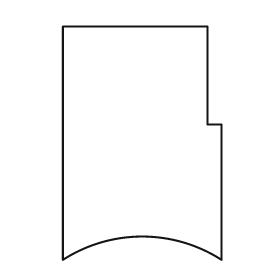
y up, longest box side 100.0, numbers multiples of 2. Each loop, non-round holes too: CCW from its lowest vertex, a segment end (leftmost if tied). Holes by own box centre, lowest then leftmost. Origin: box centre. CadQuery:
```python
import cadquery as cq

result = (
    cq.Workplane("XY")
    .moveTo(-34.0, -50.0)
    .threePointArc((0.0, -40.0), (34.0, -50.0))
    .lineTo(34.0, 8.0)
    .lineTo(28.0, 8.0)
    .lineTo(28.0, 50.0)
    .lineTo(-34.0, 50.0)
    .close()
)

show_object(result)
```